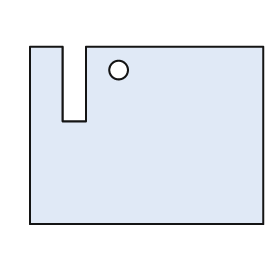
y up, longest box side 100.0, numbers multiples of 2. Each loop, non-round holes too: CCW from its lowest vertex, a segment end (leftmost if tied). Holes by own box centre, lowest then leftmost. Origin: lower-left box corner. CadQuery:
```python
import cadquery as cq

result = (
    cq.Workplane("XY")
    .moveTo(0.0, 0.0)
    .lineTo(100.0, 0.0)
    .lineTo(100.0, 76.0)
    .lineTo(24.0, 76.0)
    .lineTo(24.0, 44.0)
    .lineTo(14.0, 44.0)
    .lineTo(14.0, 76.0)
    .lineTo(0.0, 76.0)
    .close()
    .moveTo(38.0, 66.0)
    .circle(4.0)
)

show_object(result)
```